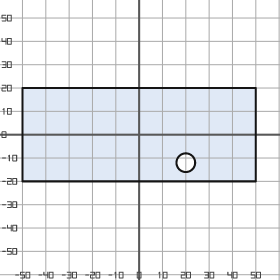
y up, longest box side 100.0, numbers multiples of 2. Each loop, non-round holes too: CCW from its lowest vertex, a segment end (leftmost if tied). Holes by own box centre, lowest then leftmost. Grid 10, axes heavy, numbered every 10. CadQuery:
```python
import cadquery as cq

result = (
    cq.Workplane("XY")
    .moveTo(-50.0, -20.0)
    .lineTo(50.0, -20.0)
    .lineTo(50.0, 20.0)
    .lineTo(-50.0, 20.0)
    .close()
    .moveTo(20.0, -12.0)
    .circle(4.0)
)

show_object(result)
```